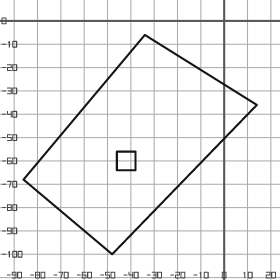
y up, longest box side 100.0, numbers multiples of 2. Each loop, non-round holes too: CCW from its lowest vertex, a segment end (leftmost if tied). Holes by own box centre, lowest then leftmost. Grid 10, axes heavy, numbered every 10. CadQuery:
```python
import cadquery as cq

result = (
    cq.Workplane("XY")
    .moveTo(-48.0, -100.0)
    .lineTo(14.0, -36.0)
    .lineTo(-34.0, -6.0)
    .lineTo(-86.0, -68.0)
    .close()
    .moveTo(-46.0, -64.0)
    .lineTo(-38.0, -64.0)
    .lineTo(-38.0, -56.0)
    .lineTo(-46.0, -56.0)
    .close()
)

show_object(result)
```